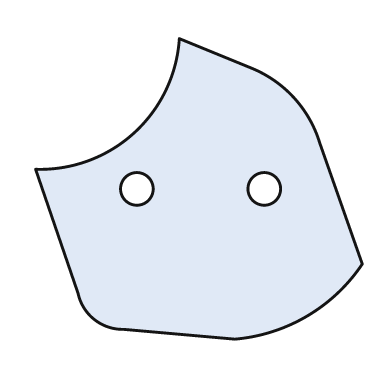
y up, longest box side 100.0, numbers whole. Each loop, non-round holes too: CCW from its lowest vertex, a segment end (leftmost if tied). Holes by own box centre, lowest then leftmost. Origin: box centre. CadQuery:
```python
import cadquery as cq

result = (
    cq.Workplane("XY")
    .moveTo(11.0, -46.0)
    .threePointArc((33.0, -39.0), (50.0, -23.0))
    .lineTo(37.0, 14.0)
    .threePointArc((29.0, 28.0), (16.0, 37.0))
    .lineTo(-6.0, 46.0)
    .threePointArc((-20.0, 17.0), (-50.0, 6.0))
    .lineTo(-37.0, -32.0)
    .threePointArc((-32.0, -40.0), (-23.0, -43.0))
    .close()
    .moveTo(-19.0, 0.0)
    .circle(5.0)
    .moveTo(20.0, 0.0)
    .circle(5.0)
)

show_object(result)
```